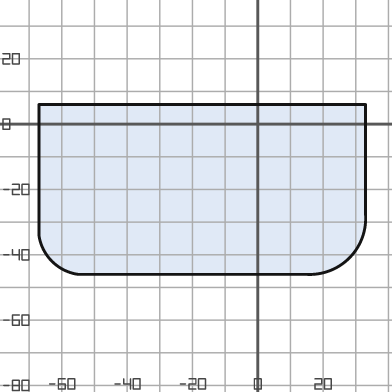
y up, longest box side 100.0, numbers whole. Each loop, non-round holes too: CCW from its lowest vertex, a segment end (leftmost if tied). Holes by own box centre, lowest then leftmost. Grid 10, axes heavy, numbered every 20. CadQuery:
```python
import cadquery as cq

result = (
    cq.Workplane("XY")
    .moveTo(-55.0, -46.0)
    .lineTo(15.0, -46.0)
    .threePointArc((28.0, -41.0), (33.0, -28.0))
    .lineTo(33.0, 6.0)
    .lineTo(-67.0, 6.0)
    .lineTo(-67.0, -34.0)
    .threePointArc((-63.0, -42.0), (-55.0, -46.0))
    .close()
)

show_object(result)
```